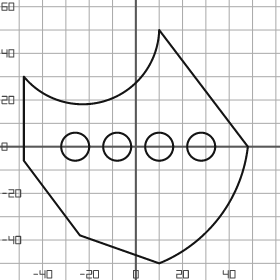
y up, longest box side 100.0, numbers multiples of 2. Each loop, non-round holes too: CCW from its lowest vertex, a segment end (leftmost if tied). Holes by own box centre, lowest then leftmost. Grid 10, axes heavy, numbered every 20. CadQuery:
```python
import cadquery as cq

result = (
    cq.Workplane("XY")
    .moveTo(10.0, -50.0)
    .threePointArc((36.0, -30.0), (48.0, 0.0))
    .lineTo(10.0, 50.0)
    .threePointArc((-12.0, 20.0), (-48.0, 30.0))
    .lineTo(-48.0, -6.0)
    .lineTo(-24.0, -38.0)
    .close()
    .moveTo(-26.0, 0.0)
    .circle(6.0)
    .moveTo(-8.0, 0.0)
    .circle(6.0)
    .moveTo(10.0, 0.0)
    .circle(6.0)
    .moveTo(28.0, 0.0)
    .circle(6.0)
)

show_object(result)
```